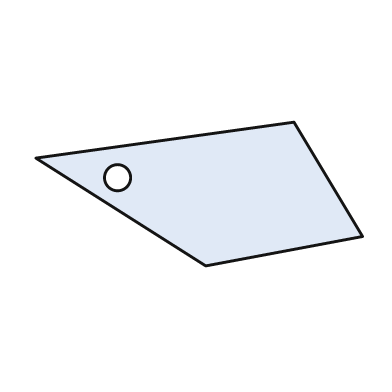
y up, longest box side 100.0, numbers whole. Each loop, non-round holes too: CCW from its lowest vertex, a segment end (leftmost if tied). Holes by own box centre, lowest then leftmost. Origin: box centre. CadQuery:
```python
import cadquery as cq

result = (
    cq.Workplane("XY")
    .moveTo(2.0, -22.0)
    .lineTo(50.0, -13.0)
    .lineTo(29.0, 22.0)
    .lineTo(-50.0, 11.0)
    .close()
    .moveTo(-25.0, 5.0)
    .circle(4.0)
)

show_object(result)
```